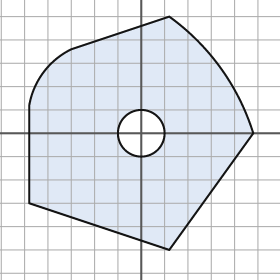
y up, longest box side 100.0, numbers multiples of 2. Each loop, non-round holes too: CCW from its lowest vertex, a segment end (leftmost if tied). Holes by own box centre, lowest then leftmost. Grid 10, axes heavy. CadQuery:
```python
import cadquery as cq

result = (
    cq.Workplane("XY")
    .moveTo(12.0, -50.0)
    .lineTo(48.0, 0.0)
    .threePointArc((34.0, 28.0), (12.0, 50.0))
    .lineTo(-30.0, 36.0)
    .threePointArc((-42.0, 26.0), (-48.0, 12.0))
    .lineTo(-48.0, -30.0)
    .close()
    .moveTo(0.0, 0.0)
    .circle(10.0)
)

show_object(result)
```